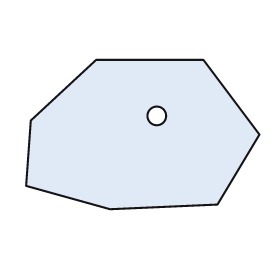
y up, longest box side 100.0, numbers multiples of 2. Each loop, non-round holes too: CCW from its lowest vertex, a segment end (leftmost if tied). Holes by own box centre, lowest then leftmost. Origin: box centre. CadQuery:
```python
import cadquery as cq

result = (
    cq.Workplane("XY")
    .moveTo(-14.0, -32.0)
    .lineTo(32.0, -30.0)
    .lineTo(50.0, 0.0)
    .lineTo(26.0, 32.0)
    .lineTo(-20.0, 32.0)
    .lineTo(-48.0, 6.0)
    .lineTo(-50.0, -22.0)
    .close()
    .moveTo(6.0, 8.0)
    .circle(4.0)
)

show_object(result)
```